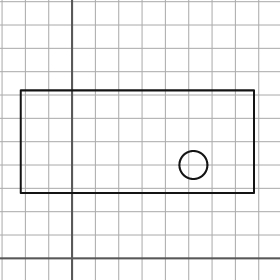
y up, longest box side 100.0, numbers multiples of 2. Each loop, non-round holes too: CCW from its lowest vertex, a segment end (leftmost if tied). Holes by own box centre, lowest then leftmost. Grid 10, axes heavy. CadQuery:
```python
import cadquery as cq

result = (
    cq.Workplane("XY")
    .moveTo(-22.0, 28.0)
    .lineTo(78.0, 28.0)
    .lineTo(78.0, 72.0)
    .lineTo(-22.0, 72.0)
    .close()
    .moveTo(52.0, 40.0)
    .circle(6.0)
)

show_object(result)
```